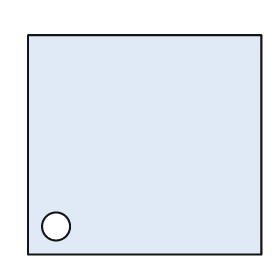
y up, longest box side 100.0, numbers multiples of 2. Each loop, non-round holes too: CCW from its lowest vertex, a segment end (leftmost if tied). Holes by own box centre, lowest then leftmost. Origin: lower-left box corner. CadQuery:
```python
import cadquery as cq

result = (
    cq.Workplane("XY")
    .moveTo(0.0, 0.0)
    .lineTo(100.0, 0.0)
    .lineTo(100.0, 94.0)
    .lineTo(0.0, 94.0)
    .close()
    .moveTo(12.0, 12.0)
    .circle(6.0)
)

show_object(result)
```